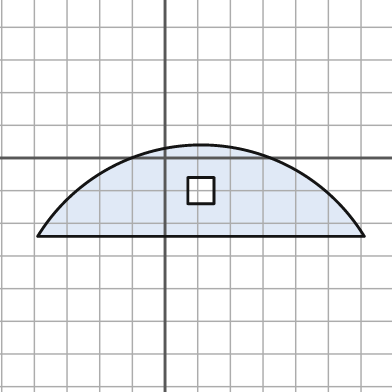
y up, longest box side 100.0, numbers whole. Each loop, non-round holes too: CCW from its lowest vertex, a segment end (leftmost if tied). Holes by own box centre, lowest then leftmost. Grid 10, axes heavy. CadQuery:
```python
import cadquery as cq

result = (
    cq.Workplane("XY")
    .moveTo(-39.0, -24.0)
    .lineTo(61.0, -24.0)
    .threePointArc((11.0, 4.0), (-39.0, -24.0))
    .close()
    .moveTo(7.0, -14.0)
    .lineTo(15.0, -14.0)
    .lineTo(15.0, -6.0)
    .lineTo(7.0, -6.0)
    .close()
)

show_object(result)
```